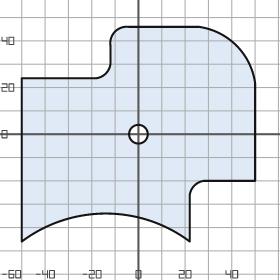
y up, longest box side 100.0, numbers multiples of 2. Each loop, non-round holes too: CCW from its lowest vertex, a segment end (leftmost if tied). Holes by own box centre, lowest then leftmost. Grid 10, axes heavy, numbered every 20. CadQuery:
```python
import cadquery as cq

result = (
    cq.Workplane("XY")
    .moveTo(-50.0, -46.0)
    .threePointArc((-14.0, -34.0), (22.0, -46.0))
    .lineTo(22.0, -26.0)
    .threePointArc((24.0, -22.0), (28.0, -20.0))
    .lineTo(50.0, -20.0)
    .lineTo(50.0, 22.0)
    .threePointArc((42.0, 38.0), (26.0, 46.0))
    .lineTo(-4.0, 46.0)
    .threePointArc((-10.0, 44.0), (-12.0, 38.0))
    .lineTo(-12.0, 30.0)
    .threePointArc((-14.0, 26.0), (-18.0, 24.0))
    .lineTo(-50.0, 24.0)
    .close()
    .moveTo(0.0, 0.0)
    .circle(4.0)
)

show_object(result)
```